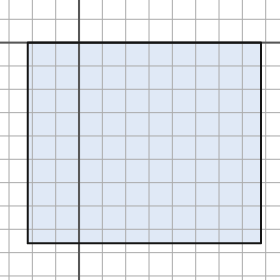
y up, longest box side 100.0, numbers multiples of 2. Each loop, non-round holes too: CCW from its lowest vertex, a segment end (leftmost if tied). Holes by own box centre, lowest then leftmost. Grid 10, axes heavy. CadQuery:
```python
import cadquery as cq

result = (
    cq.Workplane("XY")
    .moveTo(-22.0, -86.0)
    .lineTo(78.0, -86.0)
    .lineTo(78.0, 0.0)
    .lineTo(-22.0, 0.0)
    .close()
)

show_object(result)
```